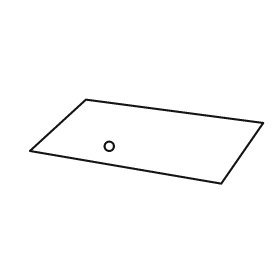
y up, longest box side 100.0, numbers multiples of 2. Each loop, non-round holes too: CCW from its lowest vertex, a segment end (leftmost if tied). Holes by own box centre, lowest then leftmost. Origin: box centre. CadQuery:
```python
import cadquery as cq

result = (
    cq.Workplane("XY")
    .moveTo(32.0, -18.0)
    .lineTo(50.0, 8.0)
    .lineTo(-26.0, 18.0)
    .lineTo(-50.0, -4.0)
    .close()
    .moveTo(-16.0, -2.0)
    .circle(2.0)
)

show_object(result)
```